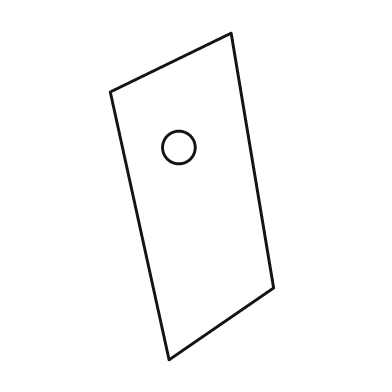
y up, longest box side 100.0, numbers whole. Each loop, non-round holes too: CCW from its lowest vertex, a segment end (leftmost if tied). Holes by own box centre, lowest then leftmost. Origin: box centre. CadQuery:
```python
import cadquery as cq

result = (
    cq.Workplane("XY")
    .moveTo(-7.0, -50.0)
    .lineTo(25.0, -28.0)
    .lineTo(12.0, 50.0)
    .lineTo(-25.0, 32.0)
    .close()
    .moveTo(-4.0, 15.0)
    .circle(5.0)
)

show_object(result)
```